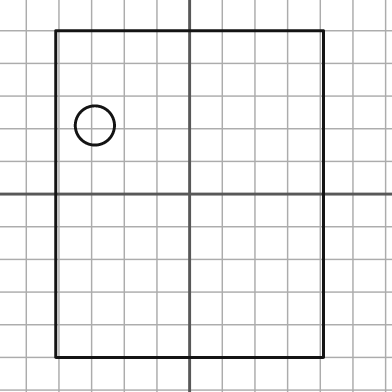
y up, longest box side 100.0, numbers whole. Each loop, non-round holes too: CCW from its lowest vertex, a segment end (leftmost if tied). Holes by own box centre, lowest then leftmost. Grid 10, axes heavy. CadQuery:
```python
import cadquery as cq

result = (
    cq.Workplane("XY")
    .moveTo(-41.0, -50.0)
    .lineTo(41.0, -50.0)
    .lineTo(41.0, 50.0)
    .lineTo(-41.0, 50.0)
    .close()
    .moveTo(-29.0, 21.0)
    .circle(6.0)
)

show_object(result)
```